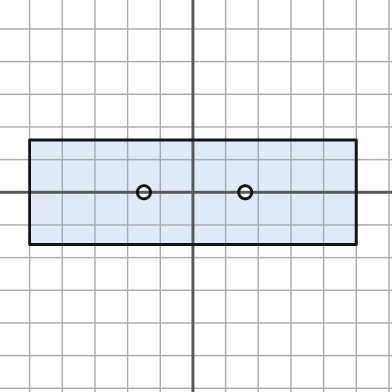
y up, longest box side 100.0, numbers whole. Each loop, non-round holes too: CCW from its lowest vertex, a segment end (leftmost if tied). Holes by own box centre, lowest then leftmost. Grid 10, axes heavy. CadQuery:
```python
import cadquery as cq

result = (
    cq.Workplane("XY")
    .moveTo(-50.0, -16.0)
    .lineTo(50.0, -16.0)
    .lineTo(50.0, 16.0)
    .lineTo(-50.0, 16.0)
    .close()
    .moveTo(-15.0, 0.0)
    .circle(2.0)
    .moveTo(16.0, 0.0)
    .circle(2.0)
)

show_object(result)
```